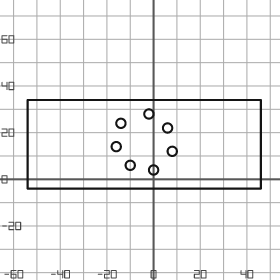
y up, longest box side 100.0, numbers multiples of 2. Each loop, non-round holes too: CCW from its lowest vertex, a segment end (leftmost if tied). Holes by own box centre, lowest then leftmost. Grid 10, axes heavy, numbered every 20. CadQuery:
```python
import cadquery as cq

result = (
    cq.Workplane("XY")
    .moveTo(-54.0, -4.0)
    .lineTo(46.0, -4.0)
    .lineTo(46.0, 34.0)
    .lineTo(-54.0, 34.0)
    .close()
    .moveTo(0.0, 4.0)
    .circle(2.0)
    .moveTo(-10.0, 6.0)
    .circle(2.0)
    .moveTo(8.0, 12.0)
    .circle(2.0)
    .moveTo(-16.0, 14.0)
    .circle(2.0)
    .moveTo(6.0, 22.0)
    .circle(2.0)
    .moveTo(-14.0, 24.0)
    .circle(2.0)
    .moveTo(-2.0, 28.0)
    .circle(2.0)
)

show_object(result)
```